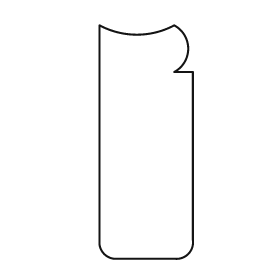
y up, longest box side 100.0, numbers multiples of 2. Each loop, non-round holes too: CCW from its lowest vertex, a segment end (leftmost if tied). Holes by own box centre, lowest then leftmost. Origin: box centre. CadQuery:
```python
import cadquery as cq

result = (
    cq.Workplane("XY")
    .moveTo(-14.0, -50.0)
    .lineTo(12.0, -50.0)
    .threePointArc((18.0, -48.0), (20.0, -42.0))
    .lineTo(20.0, 30.0)
    .lineTo(12.0, 30.0)
    .threePointArc((18.0, 40.0), (12.0, 50.0))
    .threePointArc((-4.0, 46.0), (-20.0, 50.0))
    .lineTo(-20.0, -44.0)
    .threePointArc((-18.0, -48.0), (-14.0, -50.0))
    .close()
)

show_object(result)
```